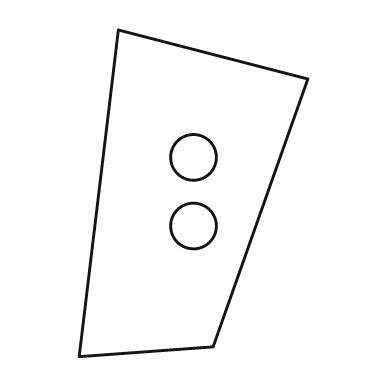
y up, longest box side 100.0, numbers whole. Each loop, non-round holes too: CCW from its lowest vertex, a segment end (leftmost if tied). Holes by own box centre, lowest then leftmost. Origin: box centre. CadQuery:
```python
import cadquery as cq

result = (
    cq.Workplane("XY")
    .moveTo(-35.0, -50.0)
    .lineTo(6.0, -47.0)
    .lineTo(35.0, 35.0)
    .lineTo(-23.0, 50.0)
    .close()
    .moveTo(0.0, -10.0)
    .circle(7.0)
    .moveTo(0.0, 11.0)
    .circle(7.0)
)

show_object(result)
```